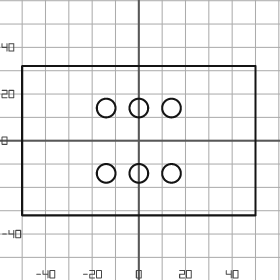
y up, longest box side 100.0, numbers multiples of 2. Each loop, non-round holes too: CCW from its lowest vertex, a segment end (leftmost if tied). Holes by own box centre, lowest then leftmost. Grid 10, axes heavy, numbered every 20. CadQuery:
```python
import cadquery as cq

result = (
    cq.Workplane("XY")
    .moveTo(-50.0, -32.0)
    .lineTo(50.0, -32.0)
    .lineTo(50.0, 32.0)
    .lineTo(-50.0, 32.0)
    .close()
    .moveTo(-14.0, -14.0)
    .circle(4.0)
    .moveTo(0.0, -14.0)
    .circle(4.0)
    .moveTo(14.0, -14.0)
    .circle(4.0)
    .moveTo(-14.0, 14.0)
    .circle(4.0)
    .moveTo(0.0, 14.0)
    .circle(4.0)
    .moveTo(14.0, 14.0)
    .circle(4.0)
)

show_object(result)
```